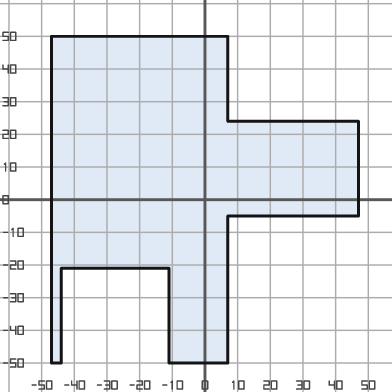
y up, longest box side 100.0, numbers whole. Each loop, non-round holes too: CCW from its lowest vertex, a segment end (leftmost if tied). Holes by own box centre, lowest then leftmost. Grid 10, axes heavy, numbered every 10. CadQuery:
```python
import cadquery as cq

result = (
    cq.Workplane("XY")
    .moveTo(-47.0, -50.0)
    .lineTo(-44.0, -50.0)
    .lineTo(-44.0, -21.0)
    .lineTo(-11.0, -21.0)
    .lineTo(-11.0, -50.0)
    .lineTo(7.0, -50.0)
    .lineTo(7.0, -5.0)
    .lineTo(47.0, -5.0)
    .lineTo(47.0, 24.0)
    .lineTo(7.0, 24.0)
    .lineTo(7.0, 50.0)
    .lineTo(-47.0, 50.0)
    .close()
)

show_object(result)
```